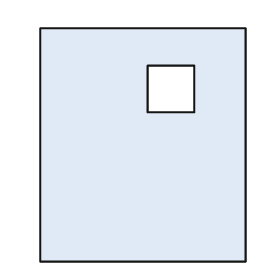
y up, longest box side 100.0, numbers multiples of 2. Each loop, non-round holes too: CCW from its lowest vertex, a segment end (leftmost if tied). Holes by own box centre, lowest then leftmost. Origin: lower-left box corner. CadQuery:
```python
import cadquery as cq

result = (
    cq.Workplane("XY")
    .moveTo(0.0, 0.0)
    .lineTo(88.0, 0.0)
    .lineTo(88.0, 100.0)
    .lineTo(0.0, 100.0)
    .close()
    .moveTo(46.0, 64.0)
    .lineTo(66.0, 64.0)
    .lineTo(66.0, 84.0)
    .lineTo(46.0, 84.0)
    .close()
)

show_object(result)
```